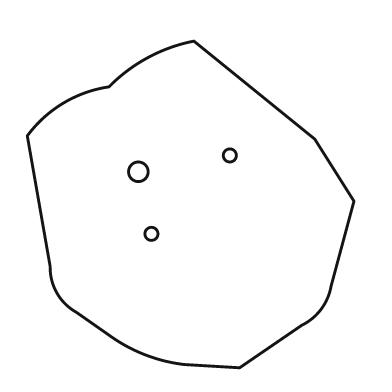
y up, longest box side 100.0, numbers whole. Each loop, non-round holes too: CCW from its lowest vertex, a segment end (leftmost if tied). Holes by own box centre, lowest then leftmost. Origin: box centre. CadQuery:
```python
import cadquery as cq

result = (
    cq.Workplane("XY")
    .moveTo(15.0, -50.0)
    .lineTo(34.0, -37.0)
    .threePointArc((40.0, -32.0), (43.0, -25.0))
    .lineTo(50.0, 1.0)
    .lineTo(38.0, 20.0)
    .lineTo(1.0, 50.0)
    .threePointArc((-13.0, 45.0), (-25.0, 36.0))
    .threePointArc((-39.0, 31.0), (-50.0, 21.0))
    .lineTo(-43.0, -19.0)
    .threePointArc((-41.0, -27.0), (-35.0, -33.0))
    .lineTo(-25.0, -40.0)
    .threePointArc((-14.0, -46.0), (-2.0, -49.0))
    .close()
    .moveTo(-12.0, -9.0)
    .circle(2.0)
    .moveTo(-16.0, 10.0)
    .circle(3.0)
    .moveTo(12.0, 15.0)
    .circle(2.0)
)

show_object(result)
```